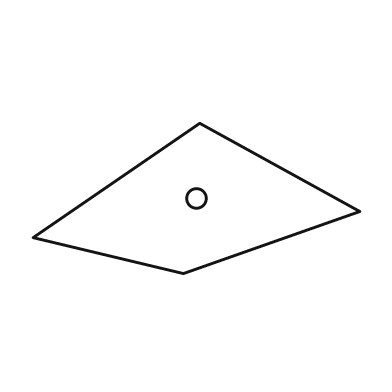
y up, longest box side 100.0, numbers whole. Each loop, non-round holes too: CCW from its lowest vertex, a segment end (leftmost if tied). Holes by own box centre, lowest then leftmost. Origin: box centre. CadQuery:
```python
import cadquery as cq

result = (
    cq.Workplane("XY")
    .moveTo(-4.0, -23.0)
    .lineTo(50.0, -4.0)
    .lineTo(1.0, 23.0)
    .lineTo(-50.0, -12.0)
    .close()
    .moveTo(0.0, 0.0)
    .circle(3.0)
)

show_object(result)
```